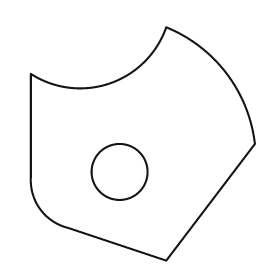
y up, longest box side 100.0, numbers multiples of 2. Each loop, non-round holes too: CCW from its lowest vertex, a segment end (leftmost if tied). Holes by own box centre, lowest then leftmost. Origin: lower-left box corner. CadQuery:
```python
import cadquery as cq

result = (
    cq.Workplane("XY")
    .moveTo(58.0, 0.0)
    .lineTo(96.0, 50.0)
    .threePointArc((84.0, 80.0), (58.0, 100.0))
    .threePointArc((34.0, 76.0), (0.0, 80.0))
    .lineTo(0.0, 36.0)
    .threePointArc((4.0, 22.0), (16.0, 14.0))
    .close()
    .moveTo(38.0, 38.0)
    .circle(12.0)
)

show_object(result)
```